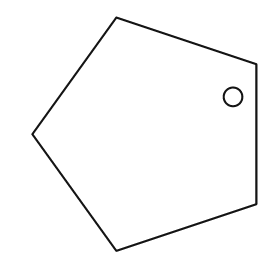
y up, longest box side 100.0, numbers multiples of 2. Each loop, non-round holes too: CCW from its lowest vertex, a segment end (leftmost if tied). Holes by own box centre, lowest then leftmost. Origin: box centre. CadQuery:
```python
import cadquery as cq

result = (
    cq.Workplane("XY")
    .moveTo(-12.0, -50.0)
    .lineTo(48.0, -30.0)
    .lineTo(48.0, 30.0)
    .lineTo(-12.0, 50.0)
    .lineTo(-48.0, 0.0)
    .close()
    .moveTo(38.0, 16.0)
    .circle(4.0)
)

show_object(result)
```